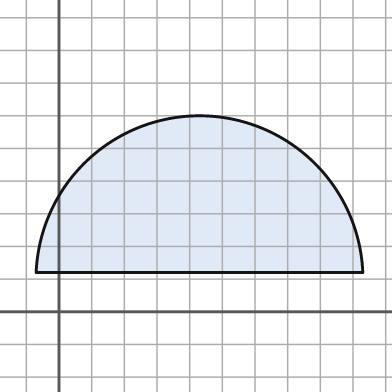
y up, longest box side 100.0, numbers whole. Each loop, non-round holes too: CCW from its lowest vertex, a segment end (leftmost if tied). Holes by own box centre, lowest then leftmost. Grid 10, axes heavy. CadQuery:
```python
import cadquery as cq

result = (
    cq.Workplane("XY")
    .moveTo(-7.0, 12.0)
    .lineTo(93.0, 12.0)
    .threePointArc((43.0, 60.0), (-7.0, 12.0))
    .close()
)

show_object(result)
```